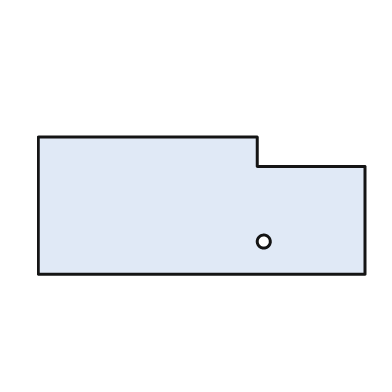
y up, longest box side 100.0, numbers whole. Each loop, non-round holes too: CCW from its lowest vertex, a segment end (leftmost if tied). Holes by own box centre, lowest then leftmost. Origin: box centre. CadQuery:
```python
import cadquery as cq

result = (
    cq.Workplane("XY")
    .moveTo(-50.0, -21.0)
    .lineTo(50.0, -21.0)
    .lineTo(50.0, 12.0)
    .lineTo(17.0, 12.0)
    .lineTo(17.0, 21.0)
    .lineTo(-50.0, 21.0)
    .close()
    .moveTo(19.0, -11.0)
    .circle(2.0)
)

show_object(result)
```